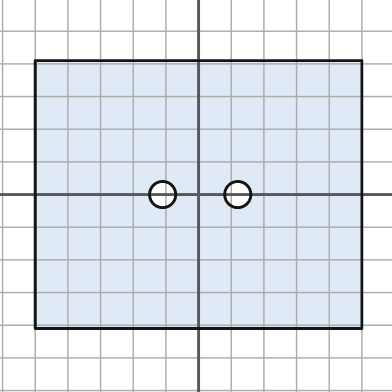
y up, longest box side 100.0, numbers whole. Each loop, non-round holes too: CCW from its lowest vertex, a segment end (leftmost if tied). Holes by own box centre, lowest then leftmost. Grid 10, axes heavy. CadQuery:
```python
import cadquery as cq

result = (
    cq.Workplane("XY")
    .moveTo(-50.0, -41.0)
    .lineTo(50.0, -41.0)
    .lineTo(50.0, 41.0)
    .lineTo(-50.0, 41.0)
    .close()
    .moveTo(-11.0, 0.0)
    .circle(4.0)
    .moveTo(12.0, 0.0)
    .circle(4.0)
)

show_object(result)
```